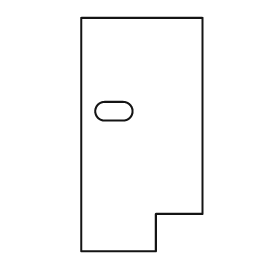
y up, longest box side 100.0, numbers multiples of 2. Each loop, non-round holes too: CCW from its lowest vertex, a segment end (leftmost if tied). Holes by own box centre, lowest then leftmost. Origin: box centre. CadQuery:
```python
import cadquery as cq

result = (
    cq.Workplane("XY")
    .moveTo(-26.0, -50.0)
    .lineTo(6.0, -50.0)
    .lineTo(6.0, -34.0)
    .lineTo(26.0, -34.0)
    .lineTo(26.0, 50.0)
    .lineTo(-26.0, 50.0)
    .close()
    .moveTo(-16.0, 6.0)
    .lineTo(-8.0, 6.0)
    .threePointArc((-4.0, 10.0), (-8.0, 14.0))
    .lineTo(-16.0, 14.0)
    .threePointArc((-20.0, 10.0), (-16.0, 6.0))
    .close()
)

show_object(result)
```